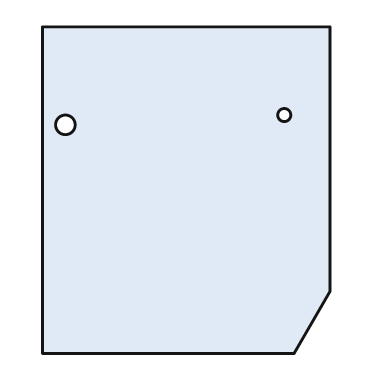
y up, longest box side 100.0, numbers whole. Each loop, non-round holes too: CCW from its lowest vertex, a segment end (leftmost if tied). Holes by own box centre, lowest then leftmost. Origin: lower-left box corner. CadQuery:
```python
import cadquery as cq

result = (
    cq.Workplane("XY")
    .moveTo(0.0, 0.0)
    .lineTo(77.0, 0.0)
    .lineTo(88.0, 19.0)
    .lineTo(88.0, 100.0)
    .lineTo(0.0, 100.0)
    .close()
    .moveTo(7.0, 70.0)
    .circle(3.0)
    .moveTo(74.0, 73.0)
    .circle(2.0)
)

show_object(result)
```